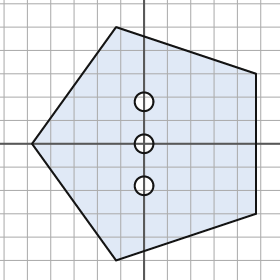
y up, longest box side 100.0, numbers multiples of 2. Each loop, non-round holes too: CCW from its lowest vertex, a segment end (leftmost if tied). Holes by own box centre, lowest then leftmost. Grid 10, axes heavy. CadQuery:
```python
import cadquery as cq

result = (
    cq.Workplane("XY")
    .moveTo(-12.0, -50.0)
    .lineTo(48.0, -30.0)
    .lineTo(48.0, 30.0)
    .lineTo(-12.0, 50.0)
    .lineTo(-48.0, 0.0)
    .close()
    .moveTo(0.0, -18.0)
    .circle(4.0)
    .moveTo(0.0, 0.0)
    .circle(4.0)
    .moveTo(0.0, 18.0)
    .circle(4.0)
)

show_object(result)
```